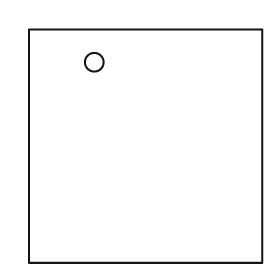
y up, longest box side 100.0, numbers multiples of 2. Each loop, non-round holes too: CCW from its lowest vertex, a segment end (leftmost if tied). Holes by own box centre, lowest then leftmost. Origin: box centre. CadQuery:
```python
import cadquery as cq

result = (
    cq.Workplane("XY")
    .moveTo(-50.0, -50.0)
    .lineTo(50.0, -50.0)
    .lineTo(50.0, 50.0)
    .lineTo(-50.0, 50.0)
    .close()
    .moveTo(-22.0, 36.0)
    .circle(4.0)
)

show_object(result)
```